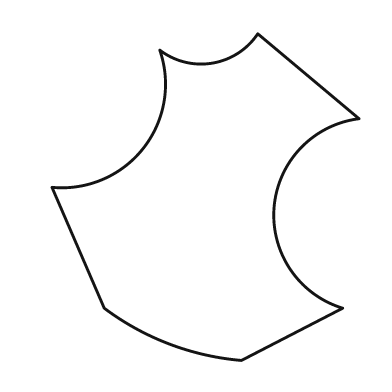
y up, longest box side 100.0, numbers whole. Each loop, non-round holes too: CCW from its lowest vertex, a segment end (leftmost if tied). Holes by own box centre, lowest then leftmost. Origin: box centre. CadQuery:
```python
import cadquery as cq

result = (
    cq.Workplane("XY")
    .moveTo(11.0, -50.0)
    .lineTo(42.0, -34.0)
    .threePointArc((21.0, -3.0), (47.0, 24.0))
    .lineTo(16.0, 50.0)
    .threePointArc((2.0, 41.0), (-14.0, 45.0))
    .threePointArc((-19.0, 15.0), (-47.0, 3.0))
    .lineTo(-31.0, -34.0)
    .threePointArc((-11.0, -45.0), (11.0, -50.0))
    .close()
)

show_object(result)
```